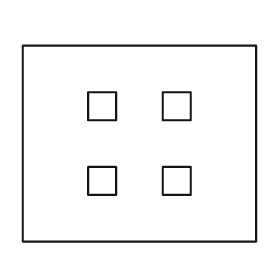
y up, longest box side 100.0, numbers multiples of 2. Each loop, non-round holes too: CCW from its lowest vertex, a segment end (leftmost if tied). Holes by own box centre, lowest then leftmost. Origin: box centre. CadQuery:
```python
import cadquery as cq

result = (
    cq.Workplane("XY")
    .moveTo(-50.0, -42.0)
    .lineTo(50.0, -42.0)
    .lineTo(50.0, 42.0)
    .lineTo(-50.0, 42.0)
    .close()
    .moveTo(-22.0, -22.0)
    .lineTo(-10.0, -22.0)
    .lineTo(-10.0, -10.0)
    .lineTo(-22.0, -10.0)
    .close()
    .moveTo(10.0, -22.0)
    .lineTo(22.0, -22.0)
    .lineTo(22.0, -10.0)
    .lineTo(10.0, -10.0)
    .close()
    .moveTo(-22.0, 10.0)
    .lineTo(-10.0, 10.0)
    .lineTo(-10.0, 22.0)
    .lineTo(-22.0, 22.0)
    .close()
    .moveTo(10.0, 10.0)
    .lineTo(22.0, 10.0)
    .lineTo(22.0, 22.0)
    .lineTo(10.0, 22.0)
    .close()
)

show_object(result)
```